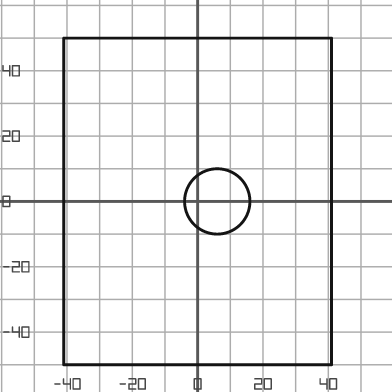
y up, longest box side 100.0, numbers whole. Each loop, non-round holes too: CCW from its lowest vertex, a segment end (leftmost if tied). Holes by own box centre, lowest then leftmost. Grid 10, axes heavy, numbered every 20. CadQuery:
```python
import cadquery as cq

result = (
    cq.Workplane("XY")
    .moveTo(-41.0, -50.0)
    .lineTo(41.0, -50.0)
    .lineTo(41.0, 50.0)
    .lineTo(-41.0, 50.0)
    .close()
    .moveTo(6.0, 0.0)
    .circle(10.0)
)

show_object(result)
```